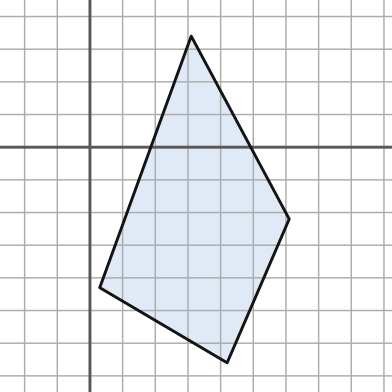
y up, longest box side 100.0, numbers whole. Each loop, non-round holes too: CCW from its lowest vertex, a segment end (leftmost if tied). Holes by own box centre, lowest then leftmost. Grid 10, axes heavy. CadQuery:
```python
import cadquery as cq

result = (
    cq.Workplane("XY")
    .moveTo(42.0, -66.0)
    .lineTo(61.0, -22.0)
    .lineTo(31.0, 34.0)
    .lineTo(3.0, -43.0)
    .close()
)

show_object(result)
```